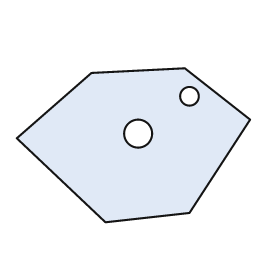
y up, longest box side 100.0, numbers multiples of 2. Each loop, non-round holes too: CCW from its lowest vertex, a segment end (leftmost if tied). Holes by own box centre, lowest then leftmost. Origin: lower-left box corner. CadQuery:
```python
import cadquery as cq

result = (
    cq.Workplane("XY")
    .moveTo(38.0, 0.0)
    .lineTo(74.0, 4.0)
    .lineTo(100.0, 44.0)
    .lineTo(72.0, 66.0)
    .lineTo(32.0, 64.0)
    .lineTo(0.0, 36.0)
    .close()
    .moveTo(52.0, 38.0)
    .circle(6.0)
    .moveTo(74.0, 54.0)
    .circle(4.0)
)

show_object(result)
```